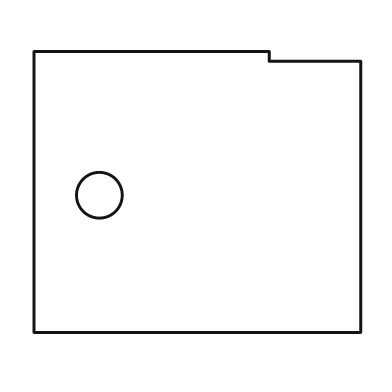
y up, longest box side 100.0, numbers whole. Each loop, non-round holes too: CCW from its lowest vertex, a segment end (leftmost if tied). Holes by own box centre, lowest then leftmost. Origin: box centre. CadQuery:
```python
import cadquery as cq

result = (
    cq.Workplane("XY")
    .moveTo(-50.0, -43.0)
    .lineTo(50.0, -43.0)
    .lineTo(50.0, 40.0)
    .lineTo(22.0, 40.0)
    .lineTo(22.0, 43.0)
    .lineTo(-50.0, 43.0)
    .close()
    .moveTo(-30.0, -1.0)
    .circle(7.0)
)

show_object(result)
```